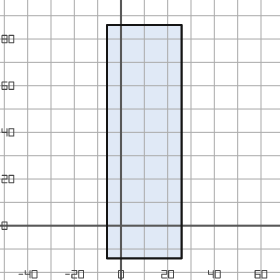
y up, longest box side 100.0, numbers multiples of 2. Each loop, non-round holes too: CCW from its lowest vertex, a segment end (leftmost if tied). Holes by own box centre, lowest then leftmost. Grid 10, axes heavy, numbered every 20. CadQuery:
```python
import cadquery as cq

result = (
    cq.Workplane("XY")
    .moveTo(-6.0, -14.0)
    .lineTo(26.0, -14.0)
    .lineTo(26.0, 86.0)
    .lineTo(-6.0, 86.0)
    .close()
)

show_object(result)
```